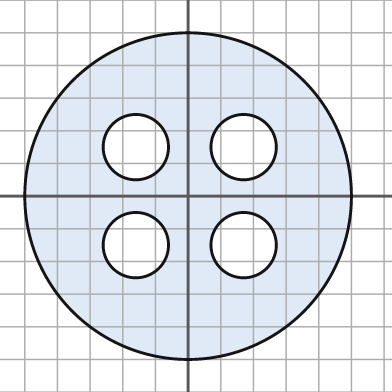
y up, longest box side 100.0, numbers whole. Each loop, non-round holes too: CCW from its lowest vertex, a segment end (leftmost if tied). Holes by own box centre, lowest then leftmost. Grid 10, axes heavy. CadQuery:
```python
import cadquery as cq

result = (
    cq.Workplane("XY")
    .moveTo(0.0, 0.0)
    .circle(50.0)
    .moveTo(-16.0, -15.0)
    .circle(10.0)
    .moveTo(17.0, -15.0)
    .circle(10.0)
    .moveTo(-16.0, 15.0)
    .circle(10.0)
    .moveTo(17.0, 15.0)
    .circle(10.0)
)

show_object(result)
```